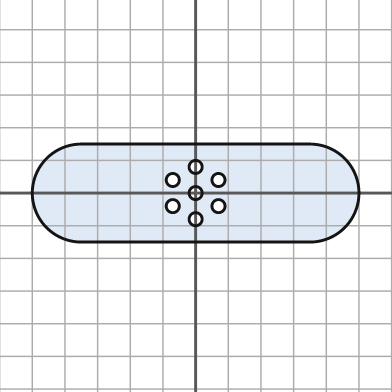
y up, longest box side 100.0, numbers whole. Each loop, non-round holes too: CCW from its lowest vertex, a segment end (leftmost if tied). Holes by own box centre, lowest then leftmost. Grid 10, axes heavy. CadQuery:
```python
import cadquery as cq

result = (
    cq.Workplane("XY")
    .moveTo(-35.0, -15.0)
    .lineTo(35.0, -15.0)
    .threePointArc((50.0, 0.0), (35.0, 15.0))
    .lineTo(-35.0, 15.0)
    .threePointArc((-50.0, 0.0), (-35.0, -15.0))
    .close()
    .moveTo(0.0, -8.0)
    .circle(2.0)
    .moveTo(-7.0, -4.0)
    .circle(2.0)
    .moveTo(7.0, -4.0)
    .circle(2.0)
    .moveTo(0.0, 0.0)
    .circle(2.0)
    .moveTo(-7.0, 4.0)
    .circle(2.0)
    .moveTo(7.0, 4.0)
    .circle(2.0)
    .moveTo(0.0, 8.0)
    .circle(2.0)
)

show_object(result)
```